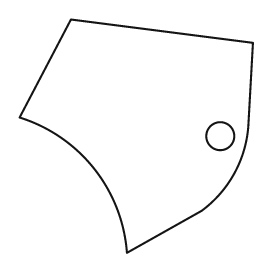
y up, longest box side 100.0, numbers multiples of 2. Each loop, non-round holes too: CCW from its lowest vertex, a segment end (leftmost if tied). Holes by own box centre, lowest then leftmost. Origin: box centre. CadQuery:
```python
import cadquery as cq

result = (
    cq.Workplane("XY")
    .moveTo(-4.0, -50.0)
    .lineTo(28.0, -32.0)
    .threePointArc((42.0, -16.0), (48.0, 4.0))
    .lineTo(50.0, 40.0)
    .lineTo(-28.0, 50.0)
    .lineTo(-50.0, 8.0)
    .threePointArc((-18.0, -14.0), (-4.0, -50.0))
    .close()
    .moveTo(36.0, 0.0)
    .circle(6.0)
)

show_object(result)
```